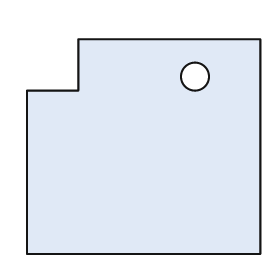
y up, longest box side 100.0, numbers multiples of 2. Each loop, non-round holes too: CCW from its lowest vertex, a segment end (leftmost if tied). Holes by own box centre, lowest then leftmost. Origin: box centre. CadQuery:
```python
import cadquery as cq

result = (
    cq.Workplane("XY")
    .moveTo(-50.0, -46.0)
    .lineTo(50.0, -46.0)
    .lineTo(50.0, 46.0)
    .lineTo(-28.0, 46.0)
    .lineTo(-28.0, 24.0)
    .lineTo(-50.0, 24.0)
    .close()
    .moveTo(22.0, 30.0)
    .circle(6.0)
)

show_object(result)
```